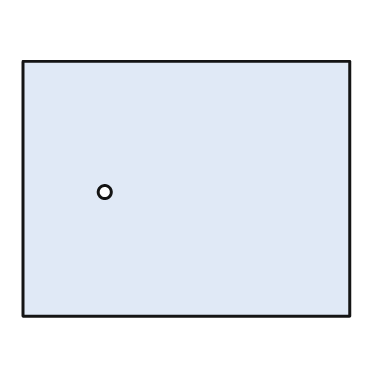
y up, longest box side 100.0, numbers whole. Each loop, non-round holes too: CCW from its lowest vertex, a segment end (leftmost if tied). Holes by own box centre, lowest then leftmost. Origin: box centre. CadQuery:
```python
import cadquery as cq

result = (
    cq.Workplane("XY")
    .moveTo(-50.0, -39.0)
    .lineTo(50.0, -39.0)
    .lineTo(50.0, 39.0)
    .lineTo(-50.0, 39.0)
    .close()
    .moveTo(-25.0, -1.0)
    .circle(2.0)
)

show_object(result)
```